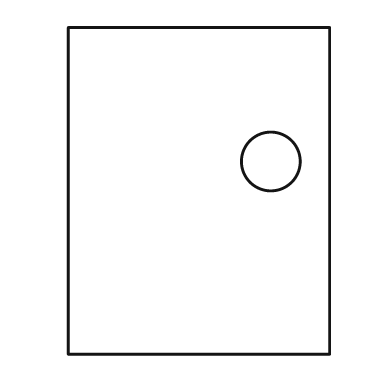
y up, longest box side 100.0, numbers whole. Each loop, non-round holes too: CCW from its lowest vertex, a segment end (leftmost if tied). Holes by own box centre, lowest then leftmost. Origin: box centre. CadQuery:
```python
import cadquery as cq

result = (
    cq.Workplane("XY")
    .moveTo(-40.0, -50.0)
    .lineTo(40.0, -50.0)
    .lineTo(40.0, 50.0)
    .lineTo(-40.0, 50.0)
    .close()
    .moveTo(22.0, 9.0)
    .circle(9.0)
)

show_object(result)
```